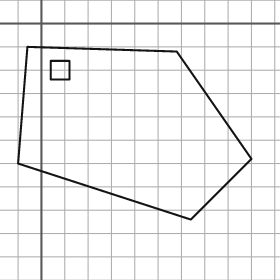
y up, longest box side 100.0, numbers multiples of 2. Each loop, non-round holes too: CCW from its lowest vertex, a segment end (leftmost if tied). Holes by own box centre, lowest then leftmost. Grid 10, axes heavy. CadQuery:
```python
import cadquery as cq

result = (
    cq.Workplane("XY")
    .moveTo(64.0, -84.0)
    .lineTo(90.0, -58.0)
    .lineTo(58.0, -12.0)
    .lineTo(-6.0, -10.0)
    .lineTo(-10.0, -60.0)
    .close()
    .moveTo(4.0, -24.0)
    .lineTo(12.0, -24.0)
    .lineTo(12.0, -16.0)
    .lineTo(4.0, -16.0)
    .close()
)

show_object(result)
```